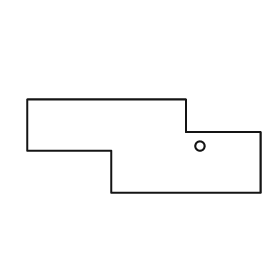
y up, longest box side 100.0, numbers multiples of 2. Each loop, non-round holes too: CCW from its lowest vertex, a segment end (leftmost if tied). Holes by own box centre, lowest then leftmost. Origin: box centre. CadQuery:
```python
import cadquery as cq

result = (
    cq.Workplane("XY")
    .moveTo(-14.0, -20.0)
    .lineTo(50.0, -20.0)
    .lineTo(50.0, 6.0)
    .lineTo(18.0, 6.0)
    .lineTo(18.0, 20.0)
    .lineTo(-50.0, 20.0)
    .lineTo(-50.0, -2.0)
    .lineTo(-14.0, -2.0)
    .close()
    .moveTo(24.0, 0.0)
    .circle(2.0)
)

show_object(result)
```